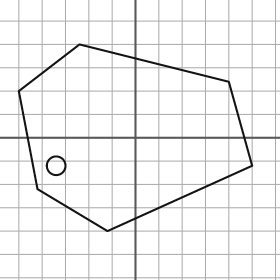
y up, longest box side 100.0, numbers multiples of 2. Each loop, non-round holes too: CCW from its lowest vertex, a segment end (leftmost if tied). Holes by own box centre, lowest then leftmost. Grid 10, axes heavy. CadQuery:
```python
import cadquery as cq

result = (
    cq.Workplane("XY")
    .moveTo(-12.0, -40.0)
    .lineTo(50.0, -12.0)
    .lineTo(40.0, 24.0)
    .lineTo(-24.0, 40.0)
    .lineTo(-50.0, 20.0)
    .lineTo(-42.0, -22.0)
    .close()
    .moveTo(-34.0, -12.0)
    .circle(4.0)
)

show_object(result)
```